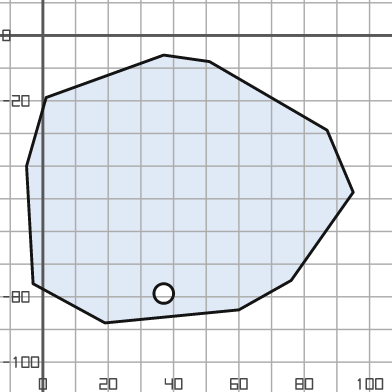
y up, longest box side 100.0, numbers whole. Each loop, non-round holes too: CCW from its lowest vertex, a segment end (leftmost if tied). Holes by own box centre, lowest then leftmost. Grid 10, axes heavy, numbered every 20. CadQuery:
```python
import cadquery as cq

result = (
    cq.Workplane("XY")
    .moveTo(19.0, -88.0)
    .lineTo(60.0, -84.0)
    .lineTo(76.0, -75.0)
    .lineTo(95.0, -48.0)
    .lineTo(87.0, -29.0)
    .lineTo(51.0, -8.0)
    .lineTo(37.0, -6.0)
    .lineTo(1.0, -19.0)
    .lineTo(-5.0, -40.0)
    .lineTo(-3.0, -76.0)
    .close()
    .moveTo(37.0, -79.0)
    .circle(3.0)
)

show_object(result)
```